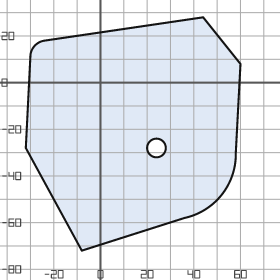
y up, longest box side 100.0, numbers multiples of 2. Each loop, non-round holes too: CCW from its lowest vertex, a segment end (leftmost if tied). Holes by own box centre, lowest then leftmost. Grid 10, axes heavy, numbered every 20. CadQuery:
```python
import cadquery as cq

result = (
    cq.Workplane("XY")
    .moveTo(-8.0, -72.0)
    .lineTo(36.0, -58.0)
    .threePointArc((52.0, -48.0), (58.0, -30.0))
    .lineTo(60.0, 8.0)
    .lineTo(44.0, 28.0)
    .lineTo(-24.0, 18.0)
    .threePointArc((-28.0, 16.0), (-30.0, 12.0))
    .lineTo(-32.0, -28.0)
    .close()
    .moveTo(24.0, -28.0)
    .circle(4.0)
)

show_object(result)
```